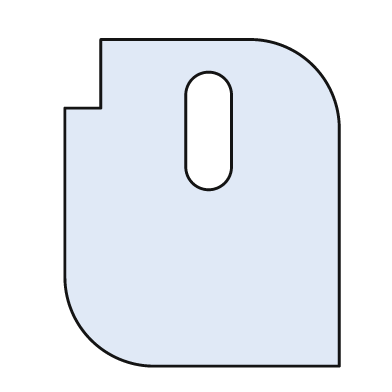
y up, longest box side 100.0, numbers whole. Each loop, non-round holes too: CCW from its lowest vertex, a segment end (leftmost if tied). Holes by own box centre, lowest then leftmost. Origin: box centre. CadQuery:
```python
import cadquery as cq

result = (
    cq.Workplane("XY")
    .moveTo(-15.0, -50.0)
    .lineTo(42.0, -50.0)
    .lineTo(42.0, 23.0)
    .threePointArc((34.0, 42.0), (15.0, 50.0))
    .lineTo(-31.0, 50.0)
    .lineTo(-31.0, 29.0)
    .lineTo(-42.0, 29.0)
    .lineTo(-42.0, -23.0)
    .threePointArc((-34.0, -42.0), (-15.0, -50.0))
    .close()
    .moveTo(-5.0, 11.0)
    .threePointArc((2.0, 4.0), (9.0, 11.0))
    .lineTo(9.0, 33.0)
    .threePointArc((2.0, 40.0), (-5.0, 33.0))
    .close()
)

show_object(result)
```